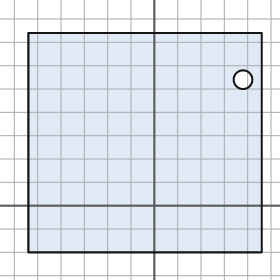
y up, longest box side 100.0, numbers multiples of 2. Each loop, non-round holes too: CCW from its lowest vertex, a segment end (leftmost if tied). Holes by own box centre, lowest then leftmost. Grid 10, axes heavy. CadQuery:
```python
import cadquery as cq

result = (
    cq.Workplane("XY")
    .moveTo(-54.0, -20.0)
    .lineTo(46.0, -20.0)
    .lineTo(46.0, 74.0)
    .lineTo(-54.0, 74.0)
    .close()
    .moveTo(38.0, 54.0)
    .circle(4.0)
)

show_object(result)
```